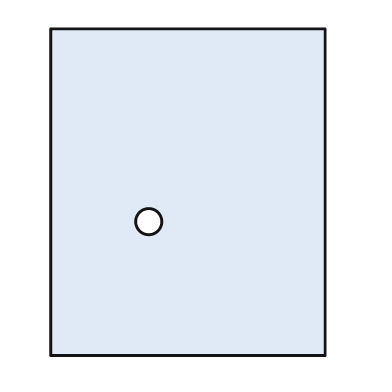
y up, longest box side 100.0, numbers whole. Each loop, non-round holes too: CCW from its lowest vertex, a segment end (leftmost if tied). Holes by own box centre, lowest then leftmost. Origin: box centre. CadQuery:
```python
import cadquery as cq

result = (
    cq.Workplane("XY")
    .moveTo(-42.0, -50.0)
    .lineTo(42.0, -50.0)
    .lineTo(42.0, 50.0)
    .lineTo(-42.0, 50.0)
    .close()
    .moveTo(-12.0, -9.0)
    .circle(4.0)
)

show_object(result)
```